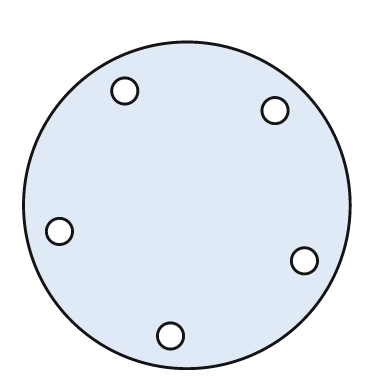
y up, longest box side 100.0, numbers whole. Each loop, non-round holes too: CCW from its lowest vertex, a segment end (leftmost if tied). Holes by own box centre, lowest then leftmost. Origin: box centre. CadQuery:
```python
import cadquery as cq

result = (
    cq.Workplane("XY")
    .moveTo(0.0, 0.0)
    .circle(50.0)
    .moveTo(-5.0, -40.0)
    .circle(4.0)
    .moveTo(36.0, -17.0)
    .circle(4.0)
    .moveTo(-39.0, -8.0)
    .circle(4.0)
    .moveTo(27.0, 29.0)
    .circle(4.0)
    .moveTo(-19.0, 35.0)
    .circle(4.0)
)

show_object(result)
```